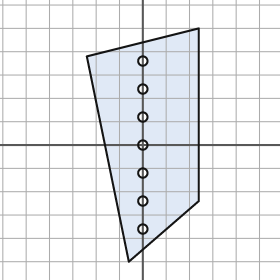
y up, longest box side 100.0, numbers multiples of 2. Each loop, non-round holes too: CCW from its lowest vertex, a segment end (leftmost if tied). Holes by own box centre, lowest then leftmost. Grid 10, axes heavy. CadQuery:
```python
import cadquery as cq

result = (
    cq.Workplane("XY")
    .moveTo(-6.0, -50.0)
    .lineTo(24.0, -24.0)
    .lineTo(24.0, 50.0)
    .lineTo(-24.0, 38.0)
    .close()
    .moveTo(0.0, -36.0)
    .circle(2.0)
    .moveTo(0.0, -24.0)
    .circle(2.0)
    .moveTo(0.0, -12.0)
    .circle(2.0)
    .moveTo(0.0, 0.0)
    .circle(2.0)
    .moveTo(0.0, 12.0)
    .circle(2.0)
    .moveTo(0.0, 24.0)
    .circle(2.0)
    .moveTo(0.0, 36.0)
    .circle(2.0)
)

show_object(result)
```